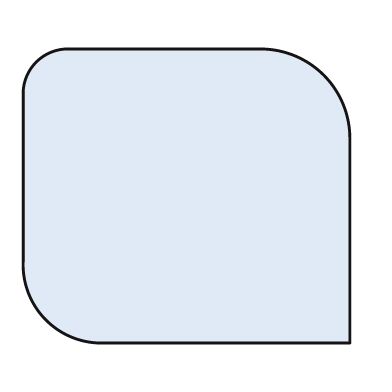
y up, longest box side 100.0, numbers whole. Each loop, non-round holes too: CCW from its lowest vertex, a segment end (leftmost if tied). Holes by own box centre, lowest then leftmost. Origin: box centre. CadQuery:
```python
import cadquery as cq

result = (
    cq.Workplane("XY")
    .moveTo(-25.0, -45.0)
    .lineTo(50.0, -45.0)
    .lineTo(50.0, 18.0)
    .threePointArc((42.0, 37.0), (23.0, 45.0))
    .lineTo(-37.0, 45.0)
    .threePointArc((-46.0, 41.0), (-50.0, 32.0))
    .lineTo(-50.0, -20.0)
    .threePointArc((-43.0, -38.0), (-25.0, -45.0))
    .close()
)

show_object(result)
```